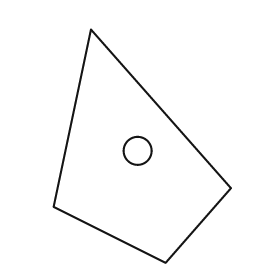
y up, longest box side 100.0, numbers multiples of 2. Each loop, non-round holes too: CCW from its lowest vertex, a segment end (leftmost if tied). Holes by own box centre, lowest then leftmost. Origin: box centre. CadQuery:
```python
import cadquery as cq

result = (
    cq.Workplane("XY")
    .moveTo(10.0, -50.0)
    .lineTo(38.0, -18.0)
    .lineTo(-22.0, 50.0)
    .lineTo(-38.0, -26.0)
    .close()
    .moveTo(-2.0, -2.0)
    .circle(6.0)
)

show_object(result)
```